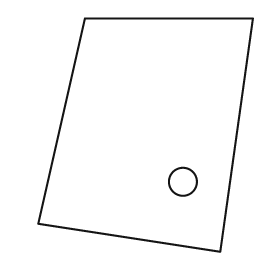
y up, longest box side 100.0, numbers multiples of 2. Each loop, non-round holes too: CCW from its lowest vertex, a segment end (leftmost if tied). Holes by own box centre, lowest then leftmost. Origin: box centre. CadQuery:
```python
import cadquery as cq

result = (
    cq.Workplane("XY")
    .moveTo(32.0, -50.0)
    .lineTo(46.0, 50.0)
    .lineTo(-26.0, 50.0)
    .lineTo(-46.0, -38.0)
    .close()
    .moveTo(16.0, -20.0)
    .circle(6.0)
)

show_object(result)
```